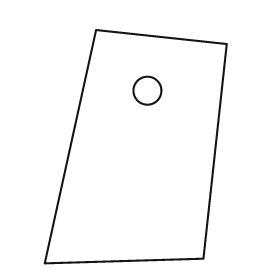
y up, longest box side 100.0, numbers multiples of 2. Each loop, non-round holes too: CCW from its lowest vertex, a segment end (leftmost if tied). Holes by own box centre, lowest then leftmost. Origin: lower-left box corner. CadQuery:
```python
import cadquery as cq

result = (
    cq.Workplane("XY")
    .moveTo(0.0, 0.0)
    .lineTo(68.0, 2.0)
    .lineTo(78.0, 94.0)
    .lineTo(22.0, 100.0)
    .close()
    .moveTo(44.0, 74.0)
    .circle(6.0)
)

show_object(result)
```